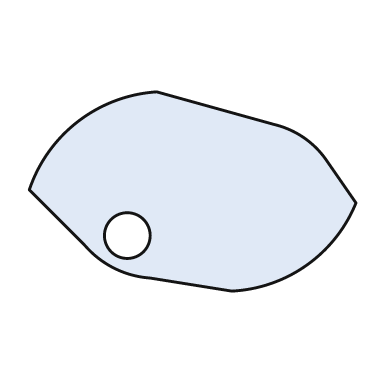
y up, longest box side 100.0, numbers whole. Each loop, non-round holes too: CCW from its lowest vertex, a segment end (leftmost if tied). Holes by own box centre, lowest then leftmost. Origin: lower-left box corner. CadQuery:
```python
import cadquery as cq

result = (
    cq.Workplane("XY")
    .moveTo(62.0, 0.0)
    .threePointArc((85.0, 8.0), (100.0, 27.0))
    .lineTo(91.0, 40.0)
    .threePointArc((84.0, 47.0), (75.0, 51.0))
    .lineTo(39.0, 61.0)
    .threePointArc((15.0, 52.0), (0.0, 31.0))
    .lineTo(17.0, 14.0)
    .threePointArc((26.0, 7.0), (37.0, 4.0))
    .close()
    .moveTo(30.0, 17.0)
    .circle(7.0)
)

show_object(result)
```